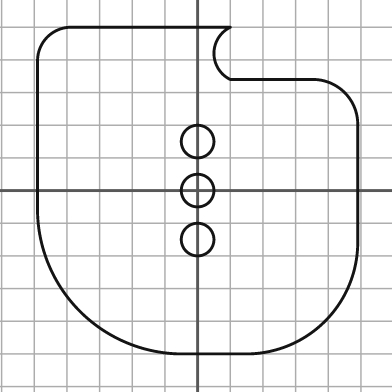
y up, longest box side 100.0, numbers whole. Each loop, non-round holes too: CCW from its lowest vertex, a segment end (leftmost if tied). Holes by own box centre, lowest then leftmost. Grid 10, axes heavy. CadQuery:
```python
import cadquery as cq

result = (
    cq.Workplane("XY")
    .moveTo(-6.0, -50.0)
    .lineTo(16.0, -50.0)
    .threePointArc((39.0, -40.0), (49.0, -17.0))
    .lineTo(49.0, 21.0)
    .threePointArc((45.0, 30.0), (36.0, 34.0))
    .lineTo(10.0, 34.0)
    .threePointArc((5.0, 42.0), (10.0, 50.0))
    .lineTo(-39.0, 50.0)
    .threePointArc((-46.0, 47.0), (-49.0, 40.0))
    .lineTo(-49.0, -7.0)
    .threePointArc((-36.0, -37.0), (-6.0, -50.0))
    .close()
    .moveTo(0.0, -15.0)
    .circle(5.0)
    .moveTo(0.0, 0.0)
    .circle(5.0)
    .moveTo(0.0, 15.0)
    .circle(5.0)
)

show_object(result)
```